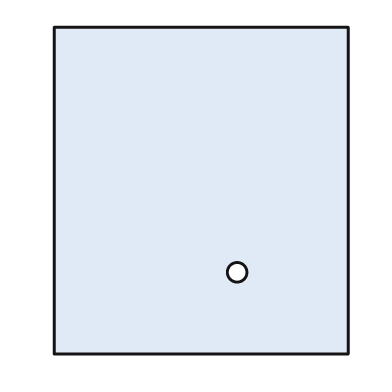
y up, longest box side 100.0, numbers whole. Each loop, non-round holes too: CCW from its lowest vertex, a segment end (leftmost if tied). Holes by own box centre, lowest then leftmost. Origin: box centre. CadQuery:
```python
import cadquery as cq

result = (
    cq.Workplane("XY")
    .moveTo(-45.0, -50.0)
    .lineTo(45.0, -50.0)
    .lineTo(45.0, 50.0)
    .lineTo(-45.0, 50.0)
    .close()
    .moveTo(11.0, -25.0)
    .circle(3.0)
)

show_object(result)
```